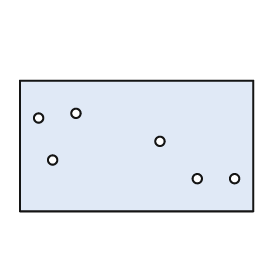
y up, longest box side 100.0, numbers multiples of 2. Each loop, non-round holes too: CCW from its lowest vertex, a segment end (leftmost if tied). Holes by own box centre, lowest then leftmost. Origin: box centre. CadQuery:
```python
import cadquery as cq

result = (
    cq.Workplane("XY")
    .moveTo(-50.0, -28.0)
    .lineTo(50.0, -28.0)
    .lineTo(50.0, 28.0)
    .lineTo(-50.0, 28.0)
    .close()
    .moveTo(26.0, -14.0)
    .circle(2.0)
    .moveTo(42.0, -14.0)
    .circle(2.0)
    .moveTo(-36.0, -6.0)
    .circle(2.0)
    .moveTo(10.0, 2.0)
    .circle(2.0)
    .moveTo(-42.0, 12.0)
    .circle(2.0)
    .moveTo(-26.0, 14.0)
    .circle(2.0)
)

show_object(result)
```